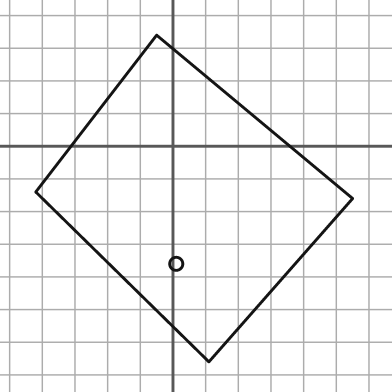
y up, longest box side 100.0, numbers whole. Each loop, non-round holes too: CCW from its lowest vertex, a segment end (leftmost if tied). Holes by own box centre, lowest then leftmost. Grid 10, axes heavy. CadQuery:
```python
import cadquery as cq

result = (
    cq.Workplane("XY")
    .moveTo(11.0, -66.0)
    .lineTo(55.0, -16.0)
    .lineTo(-5.0, 34.0)
    .lineTo(-42.0, -14.0)
    .close()
    .moveTo(1.0, -36.0)
    .circle(2.0)
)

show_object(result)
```